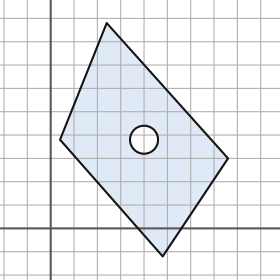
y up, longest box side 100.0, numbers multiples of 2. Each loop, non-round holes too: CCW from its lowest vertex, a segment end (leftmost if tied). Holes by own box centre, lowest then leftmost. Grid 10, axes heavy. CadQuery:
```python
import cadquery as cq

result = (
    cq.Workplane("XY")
    .moveTo(48.0, -12.0)
    .lineTo(76.0, 30.0)
    .lineTo(24.0, 88.0)
    .lineTo(4.0, 38.0)
    .close()
    .moveTo(40.0, 38.0)
    .circle(6.0)
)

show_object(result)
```